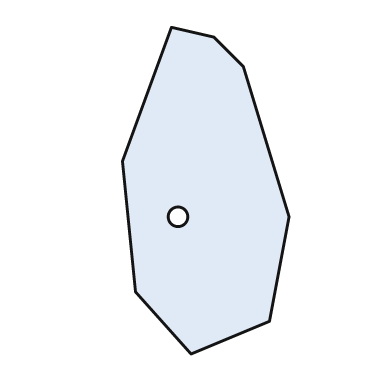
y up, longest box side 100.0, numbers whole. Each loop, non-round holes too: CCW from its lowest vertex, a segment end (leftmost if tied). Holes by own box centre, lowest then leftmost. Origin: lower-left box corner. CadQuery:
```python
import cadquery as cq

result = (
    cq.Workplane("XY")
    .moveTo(21.0, 0.0)
    .lineTo(45.0, 10.0)
    .lineTo(51.0, 42.0)
    .lineTo(37.0, 88.0)
    .lineTo(28.0, 97.0)
    .lineTo(15.0, 100.0)
    .lineTo(0.0, 59.0)
    .lineTo(4.0, 19.0)
    .close()
    .moveTo(17.0, 42.0)
    .circle(3.0)
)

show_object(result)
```